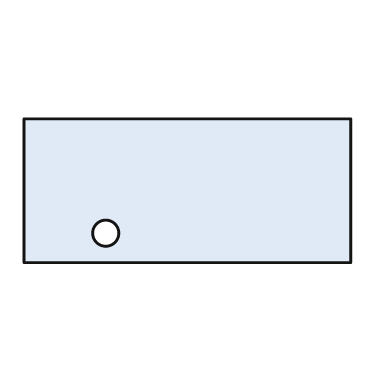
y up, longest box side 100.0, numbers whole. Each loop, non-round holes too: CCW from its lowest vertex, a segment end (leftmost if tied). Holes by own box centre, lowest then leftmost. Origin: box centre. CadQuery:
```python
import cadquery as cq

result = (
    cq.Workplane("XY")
    .moveTo(-50.0, -22.0)
    .lineTo(50.0, -22.0)
    .lineTo(50.0, 22.0)
    .lineTo(-50.0, 22.0)
    .close()
    .moveTo(-25.0, -13.0)
    .circle(4.0)
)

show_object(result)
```